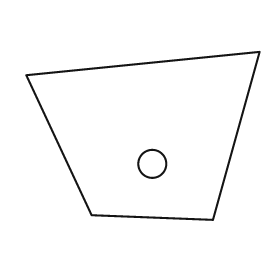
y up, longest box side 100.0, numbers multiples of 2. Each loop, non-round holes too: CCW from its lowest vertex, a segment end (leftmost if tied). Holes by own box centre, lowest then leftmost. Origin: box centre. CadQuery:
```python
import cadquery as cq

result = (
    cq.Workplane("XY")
    .moveTo(30.0, -36.0)
    .lineTo(50.0, 36.0)
    .lineTo(-50.0, 26.0)
    .lineTo(-22.0, -34.0)
    .close()
    .moveTo(4.0, -12.0)
    .circle(6.0)
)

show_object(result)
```